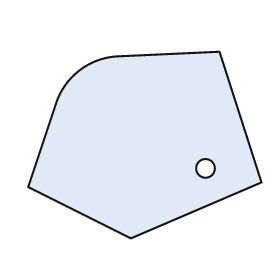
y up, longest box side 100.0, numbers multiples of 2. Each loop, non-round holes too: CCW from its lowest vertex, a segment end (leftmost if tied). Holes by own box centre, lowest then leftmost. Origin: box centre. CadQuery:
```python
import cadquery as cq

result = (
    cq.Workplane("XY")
    .moveTo(-6.0, -40.0)
    .lineTo(50.0, -16.0)
    .lineTo(32.0, 40.0)
    .lineTo(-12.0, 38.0)
    .threePointArc((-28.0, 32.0), (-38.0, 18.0))
    .lineTo(-50.0, -18.0)
    .close()
    .moveTo(26.0, -10.0)
    .circle(4.0)
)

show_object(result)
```